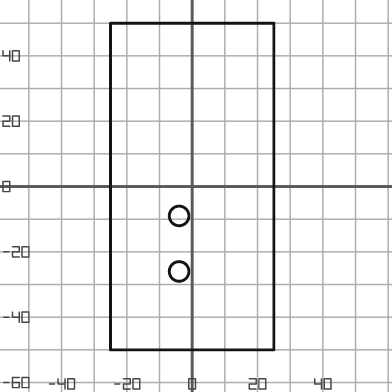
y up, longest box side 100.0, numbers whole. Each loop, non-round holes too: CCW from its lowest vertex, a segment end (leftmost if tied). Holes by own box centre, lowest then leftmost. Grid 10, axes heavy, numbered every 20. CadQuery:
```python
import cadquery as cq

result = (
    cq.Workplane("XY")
    .moveTo(-25.0, -50.0)
    .lineTo(25.0, -50.0)
    .lineTo(25.0, 50.0)
    .lineTo(-25.0, 50.0)
    .close()
    .moveTo(-4.0, -26.0)
    .circle(3.0)
    .moveTo(-4.0, -9.0)
    .circle(3.0)
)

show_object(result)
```